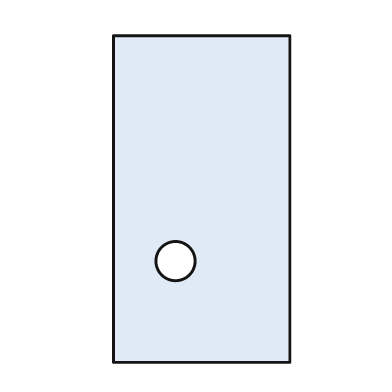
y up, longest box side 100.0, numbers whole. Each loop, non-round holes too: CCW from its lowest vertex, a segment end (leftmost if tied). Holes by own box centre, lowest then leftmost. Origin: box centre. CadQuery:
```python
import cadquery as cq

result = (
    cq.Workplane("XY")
    .moveTo(-27.0, -50.0)
    .lineTo(27.0, -50.0)
    .lineTo(27.0, 50.0)
    .lineTo(-27.0, 50.0)
    .close()
    .moveTo(-8.0, -19.0)
    .circle(6.0)
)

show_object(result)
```